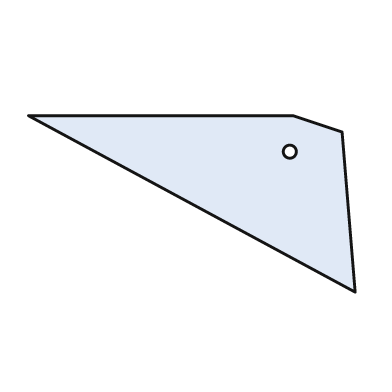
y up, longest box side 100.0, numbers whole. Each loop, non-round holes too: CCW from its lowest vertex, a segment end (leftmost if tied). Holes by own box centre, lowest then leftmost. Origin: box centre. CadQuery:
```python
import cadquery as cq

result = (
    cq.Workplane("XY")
    .moveTo(50.0, -27.0)
    .lineTo(46.0, 22.0)
    .lineTo(31.0, 27.0)
    .lineTo(-50.0, 27.0)
    .close()
    .moveTo(30.0, 16.0)
    .circle(2.0)
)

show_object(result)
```